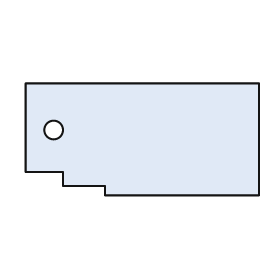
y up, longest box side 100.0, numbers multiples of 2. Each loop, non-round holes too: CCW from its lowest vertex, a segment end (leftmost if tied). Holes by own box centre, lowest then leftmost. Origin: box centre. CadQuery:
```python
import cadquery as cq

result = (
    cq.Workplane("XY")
    .moveTo(-16.0, -24.0)
    .lineTo(50.0, -24.0)
    .lineTo(50.0, 24.0)
    .lineTo(-50.0, 24.0)
    .lineTo(-50.0, -14.0)
    .lineTo(-34.0, -14.0)
    .lineTo(-34.0, -20.0)
    .lineTo(-16.0, -20.0)
    .close()
    .moveTo(-38.0, 4.0)
    .circle(4.0)
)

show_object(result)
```